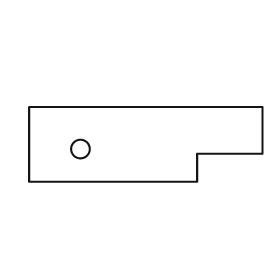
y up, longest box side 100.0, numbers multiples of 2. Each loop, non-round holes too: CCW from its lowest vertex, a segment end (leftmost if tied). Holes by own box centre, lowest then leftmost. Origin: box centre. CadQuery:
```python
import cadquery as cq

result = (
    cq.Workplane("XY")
    .moveTo(-50.0, -16.0)
    .lineTo(22.0, -16.0)
    .lineTo(22.0, -4.0)
    .lineTo(50.0, -4.0)
    .lineTo(50.0, 16.0)
    .lineTo(-50.0, 16.0)
    .close()
    .moveTo(-28.0, -2.0)
    .circle(4.0)
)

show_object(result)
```